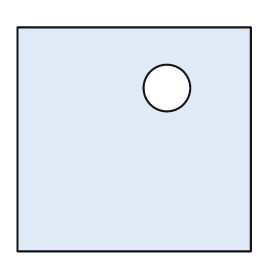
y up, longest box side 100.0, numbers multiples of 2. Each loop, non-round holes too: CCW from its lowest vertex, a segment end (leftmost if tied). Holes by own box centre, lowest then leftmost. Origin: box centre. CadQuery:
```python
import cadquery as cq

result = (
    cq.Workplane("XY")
    .moveTo(-50.0, -48.0)
    .lineTo(50.0, -48.0)
    .lineTo(50.0, 48.0)
    .lineTo(-50.0, 48.0)
    .close()
    .moveTo(14.0, 22.0)
    .circle(10.0)
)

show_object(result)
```